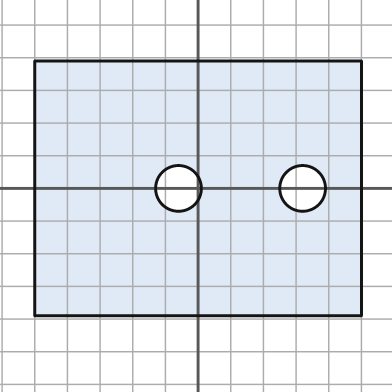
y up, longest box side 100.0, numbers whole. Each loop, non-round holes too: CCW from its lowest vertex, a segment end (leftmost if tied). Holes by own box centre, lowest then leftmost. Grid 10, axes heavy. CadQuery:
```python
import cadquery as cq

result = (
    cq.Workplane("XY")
    .moveTo(-50.0, -39.0)
    .lineTo(50.0, -39.0)
    .lineTo(50.0, 39.0)
    .lineTo(-50.0, 39.0)
    .close()
    .moveTo(-6.0, 0.0)
    .circle(7.0)
    .moveTo(32.0, 0.0)
    .circle(7.0)
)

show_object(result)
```